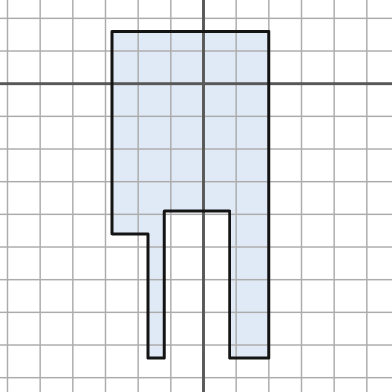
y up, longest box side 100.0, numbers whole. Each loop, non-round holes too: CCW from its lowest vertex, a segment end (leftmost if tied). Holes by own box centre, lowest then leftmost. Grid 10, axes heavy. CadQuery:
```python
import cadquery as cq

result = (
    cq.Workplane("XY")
    .moveTo(-17.0, -84.0)
    .lineTo(-12.0, -84.0)
    .lineTo(-12.0, -39.0)
    .lineTo(8.0, -39.0)
    .lineTo(8.0, -84.0)
    .lineTo(20.0, -84.0)
    .lineTo(20.0, 16.0)
    .lineTo(-28.0, 16.0)
    .lineTo(-28.0, -46.0)
    .lineTo(-17.0, -46.0)
    .close()
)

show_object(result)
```